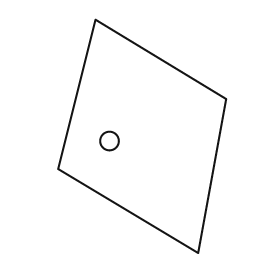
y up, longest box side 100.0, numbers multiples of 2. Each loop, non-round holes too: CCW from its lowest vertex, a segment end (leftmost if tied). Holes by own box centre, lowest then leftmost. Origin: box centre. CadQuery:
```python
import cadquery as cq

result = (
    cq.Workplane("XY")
    .moveTo(24.0, -50.0)
    .lineTo(36.0, 16.0)
    .lineTo(-20.0, 50.0)
    .lineTo(-36.0, -14.0)
    .close()
    .moveTo(-14.0, -2.0)
    .circle(4.0)
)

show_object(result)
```